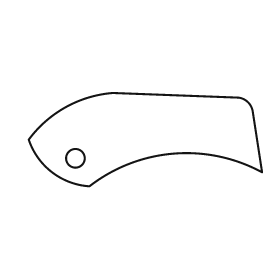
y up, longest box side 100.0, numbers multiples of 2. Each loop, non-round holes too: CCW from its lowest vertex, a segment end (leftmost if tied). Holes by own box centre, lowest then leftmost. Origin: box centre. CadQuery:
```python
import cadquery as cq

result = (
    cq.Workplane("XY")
    .moveTo(-24.0, -20.0)
    .threePointArc((12.0, -6.0), (50.0, -14.0))
    .lineTo(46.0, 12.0)
    .threePointArc((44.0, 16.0), (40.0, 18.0))
    .lineTo(-14.0, 20.0)
    .threePointArc((-34.0, 14.0), (-50.0, 0.0))
    .threePointArc((-40.0, -14.0), (-24.0, -20.0))
    .close()
    .moveTo(-30.0, -8.0)
    .circle(4.0)
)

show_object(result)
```